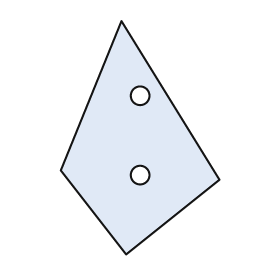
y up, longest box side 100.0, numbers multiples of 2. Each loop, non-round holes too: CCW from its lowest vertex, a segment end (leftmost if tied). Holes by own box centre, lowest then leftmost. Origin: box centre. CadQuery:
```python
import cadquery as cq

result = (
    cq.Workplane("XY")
    .moveTo(-6.0, -50.0)
    .lineTo(34.0, -18.0)
    .lineTo(-8.0, 50.0)
    .lineTo(-34.0, -14.0)
    .close()
    .moveTo(0.0, -16.0)
    .circle(4.0)
    .moveTo(0.0, 18.0)
    .circle(4.0)
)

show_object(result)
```